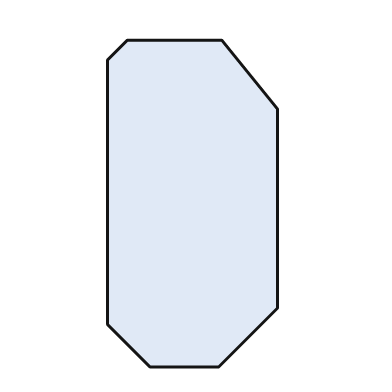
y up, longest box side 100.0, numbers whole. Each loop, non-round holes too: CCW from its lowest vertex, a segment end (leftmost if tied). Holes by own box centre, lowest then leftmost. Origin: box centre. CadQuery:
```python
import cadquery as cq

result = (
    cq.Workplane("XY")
    .moveTo(-13.0, -50.0)
    .lineTo(8.0, -50.0)
    .lineTo(26.0, -32.0)
    .lineTo(26.0, 29.0)
    .lineTo(9.0, 50.0)
    .lineTo(-20.0, 50.0)
    .lineTo(-26.0, 44.0)
    .lineTo(-26.0, -37.0)
    .close()
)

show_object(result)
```